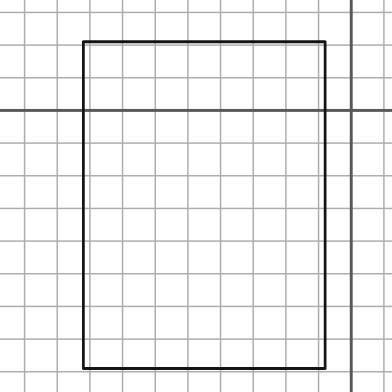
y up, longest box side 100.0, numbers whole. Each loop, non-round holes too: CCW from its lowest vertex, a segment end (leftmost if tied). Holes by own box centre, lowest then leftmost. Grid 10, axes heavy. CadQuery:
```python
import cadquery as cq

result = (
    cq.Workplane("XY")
    .moveTo(-82.0, -79.0)
    .lineTo(-8.0, -79.0)
    .lineTo(-8.0, 21.0)
    .lineTo(-82.0, 21.0)
    .close()
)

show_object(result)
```